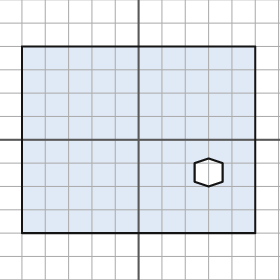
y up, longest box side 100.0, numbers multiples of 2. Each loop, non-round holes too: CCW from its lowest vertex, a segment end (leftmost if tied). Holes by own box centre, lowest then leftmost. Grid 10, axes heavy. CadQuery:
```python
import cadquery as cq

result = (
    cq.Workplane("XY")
    .moveTo(-50.0, -40.0)
    .lineTo(50.0, -40.0)
    .lineTo(50.0, 40.0)
    .lineTo(-50.0, 40.0)
    .close()
    .moveTo(30.0, -20.0)
    .lineTo(36.0, -18.0)
    .lineTo(36.0, -10.0)
    .lineTo(30.0, -8.0)
    .lineTo(24.0, -10.0)
    .lineTo(24.0, -18.0)
    .close()
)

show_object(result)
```